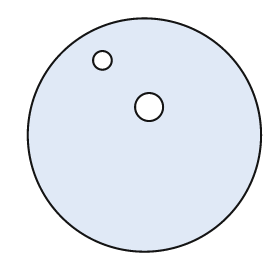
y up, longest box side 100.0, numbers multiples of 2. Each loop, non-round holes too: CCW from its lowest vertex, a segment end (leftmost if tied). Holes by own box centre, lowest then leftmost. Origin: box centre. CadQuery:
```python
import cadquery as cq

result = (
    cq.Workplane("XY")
    .moveTo(0.0, 0.0)
    .circle(50.0)
    .moveTo(2.0, 12.0)
    .circle(6.0)
    .moveTo(-18.0, 32.0)
    .circle(4.0)
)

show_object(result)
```